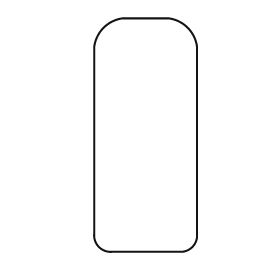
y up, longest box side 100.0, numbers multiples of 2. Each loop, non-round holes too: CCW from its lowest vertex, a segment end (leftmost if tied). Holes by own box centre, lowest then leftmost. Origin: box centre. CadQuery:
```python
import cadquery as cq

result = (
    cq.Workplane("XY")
    .moveTo(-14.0, -50.0)
    .lineTo(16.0, -50.0)
    .threePointArc((20.0, -48.0), (22.0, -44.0))
    .lineTo(22.0, 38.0)
    .threePointArc((18.0, 46.0), (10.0, 50.0))
    .lineTo(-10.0, 50.0)
    .threePointArc((-18.0, 46.0), (-22.0, 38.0))
    .lineTo(-22.0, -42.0)
    .threePointArc((-20.0, -48.0), (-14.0, -50.0))
    .close()
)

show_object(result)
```